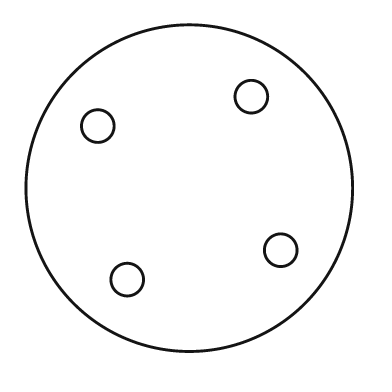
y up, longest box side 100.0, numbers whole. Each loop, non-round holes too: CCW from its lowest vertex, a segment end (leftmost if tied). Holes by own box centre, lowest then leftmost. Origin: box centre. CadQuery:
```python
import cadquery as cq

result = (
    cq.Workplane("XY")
    .moveTo(0.0, 0.0)
    .circle(50.0)
    .moveTo(-19.0, -28.0)
    .circle(5.0)
    .moveTo(28.0, -19.0)
    .circle(5.0)
    .moveTo(-28.0, 19.0)
    .circle(5.0)
    .moveTo(19.0, 28.0)
    .circle(5.0)
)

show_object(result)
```